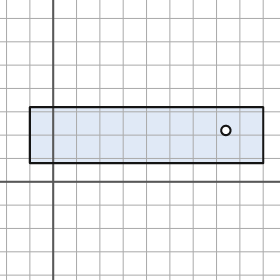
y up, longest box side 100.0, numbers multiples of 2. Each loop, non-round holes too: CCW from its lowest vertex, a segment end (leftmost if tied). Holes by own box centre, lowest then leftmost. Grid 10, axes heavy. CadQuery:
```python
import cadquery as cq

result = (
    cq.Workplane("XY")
    .moveTo(-10.0, 8.0)
    .lineTo(90.0, 8.0)
    .lineTo(90.0, 32.0)
    .lineTo(-10.0, 32.0)
    .close()
    .moveTo(74.0, 22.0)
    .circle(2.0)
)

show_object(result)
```